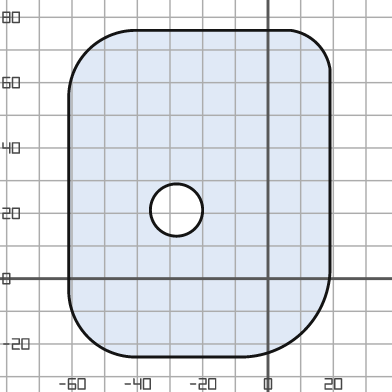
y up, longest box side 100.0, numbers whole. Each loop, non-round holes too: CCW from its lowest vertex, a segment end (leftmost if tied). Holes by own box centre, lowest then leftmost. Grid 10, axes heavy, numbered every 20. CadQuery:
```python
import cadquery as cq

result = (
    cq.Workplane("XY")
    .moveTo(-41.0, -24.0)
    .lineTo(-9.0, -24.0)
    .threePointArc((11.0, -16.0), (19.0, 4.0))
    .lineTo(19.0, 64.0)
    .threePointArc((15.0, 72.0), (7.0, 76.0))
    .lineTo(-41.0, 76.0)
    .threePointArc((-55.0, 70.0), (-61.0, 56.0))
    .lineTo(-61.0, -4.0)
    .threePointArc((-55.0, -18.0), (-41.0, -24.0))
    .close()
    .moveTo(-28.0, 21.0)
    .circle(8.0)
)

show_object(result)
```